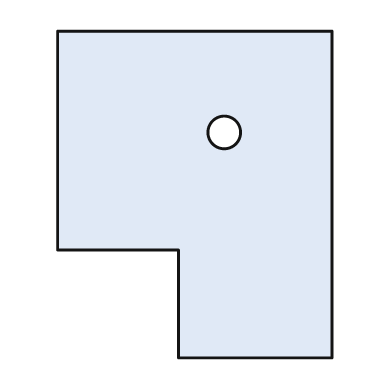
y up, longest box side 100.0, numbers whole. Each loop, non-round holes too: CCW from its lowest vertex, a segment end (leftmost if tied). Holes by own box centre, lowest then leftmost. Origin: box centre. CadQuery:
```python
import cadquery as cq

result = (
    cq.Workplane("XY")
    .moveTo(-5.0, -50.0)
    .lineTo(42.0, -50.0)
    .lineTo(42.0, 50.0)
    .lineTo(-42.0, 50.0)
    .lineTo(-42.0, -17.0)
    .lineTo(-5.0, -17.0)
    .close()
    .moveTo(9.0, 19.0)
    .circle(5.0)
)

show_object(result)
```